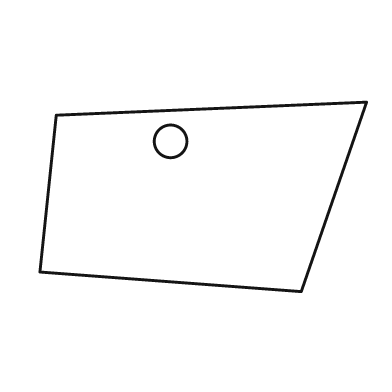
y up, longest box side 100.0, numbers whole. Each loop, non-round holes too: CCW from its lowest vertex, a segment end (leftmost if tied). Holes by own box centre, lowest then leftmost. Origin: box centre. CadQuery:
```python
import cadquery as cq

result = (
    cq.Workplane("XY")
    .moveTo(30.0, -29.0)
    .lineTo(50.0, 29.0)
    .lineTo(-45.0, 25.0)
    .lineTo(-50.0, -23.0)
    .close()
    .moveTo(-10.0, 17.0)
    .circle(5.0)
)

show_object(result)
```